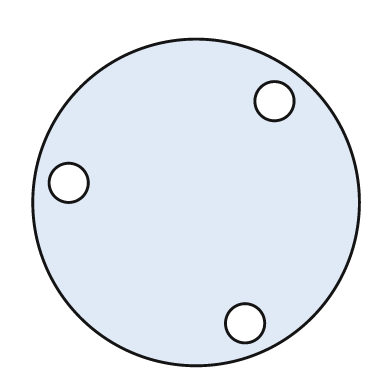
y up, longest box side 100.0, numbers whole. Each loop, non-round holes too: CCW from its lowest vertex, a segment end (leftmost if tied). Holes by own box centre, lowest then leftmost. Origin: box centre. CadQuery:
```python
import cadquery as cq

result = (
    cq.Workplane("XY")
    .moveTo(0.0, 0.0)
    .circle(50.0)
    .moveTo(15.0, -37.0)
    .circle(6.0)
    .moveTo(-39.0, 6.0)
    .circle(6.0)
    .moveTo(24.0, 31.0)
    .circle(6.0)
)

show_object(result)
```